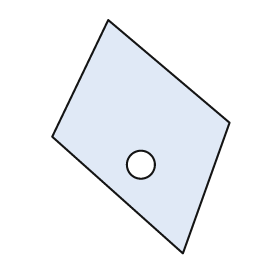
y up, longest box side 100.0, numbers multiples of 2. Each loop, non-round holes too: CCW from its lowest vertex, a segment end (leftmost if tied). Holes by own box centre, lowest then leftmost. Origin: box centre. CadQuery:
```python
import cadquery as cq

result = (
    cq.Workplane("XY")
    .moveTo(18.0, -50.0)
    .lineTo(38.0, 6.0)
    .lineTo(-14.0, 50.0)
    .lineTo(-38.0, 0.0)
    .close()
    .moveTo(0.0, -12.0)
    .circle(6.0)
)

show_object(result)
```